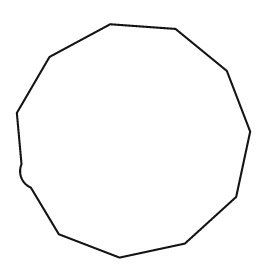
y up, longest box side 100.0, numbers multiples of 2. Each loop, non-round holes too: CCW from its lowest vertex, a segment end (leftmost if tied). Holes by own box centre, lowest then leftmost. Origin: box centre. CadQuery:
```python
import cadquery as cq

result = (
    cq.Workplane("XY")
    .moveTo(-6.0, -50.0)
    .lineTo(22.0, -44.0)
    .lineTo(44.0, -24.0)
    .lineTo(50.0, 4.0)
    .lineTo(40.0, 30.0)
    .lineTo(18.0, 48.0)
    .lineTo(-10.0, 50.0)
    .lineTo(-36.0, 36.0)
    .lineTo(-50.0, 12.0)
    .lineTo(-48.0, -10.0)
    .threePointArc((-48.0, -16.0), (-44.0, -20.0))
    .lineTo(-32.0, -40.0)
    .close()
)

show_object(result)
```